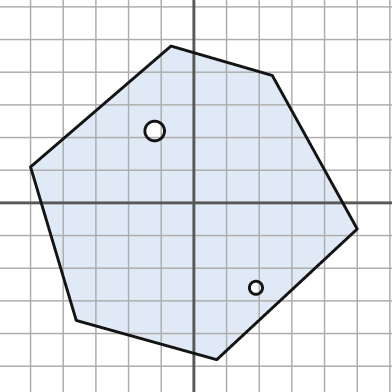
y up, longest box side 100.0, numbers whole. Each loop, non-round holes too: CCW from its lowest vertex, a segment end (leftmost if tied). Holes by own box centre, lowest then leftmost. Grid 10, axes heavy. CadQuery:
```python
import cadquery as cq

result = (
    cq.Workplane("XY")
    .moveTo(7.0, -48.0)
    .lineTo(50.0, -8.0)
    .lineTo(24.0, 39.0)
    .lineTo(-7.0, 48.0)
    .lineTo(-50.0, 11.0)
    .lineTo(-36.0, -36.0)
    .close()
    .moveTo(19.0, -26.0)
    .circle(2.0)
    .moveTo(-12.0, 22.0)
    .circle(3.0)
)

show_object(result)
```